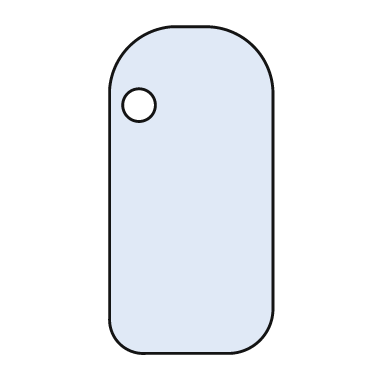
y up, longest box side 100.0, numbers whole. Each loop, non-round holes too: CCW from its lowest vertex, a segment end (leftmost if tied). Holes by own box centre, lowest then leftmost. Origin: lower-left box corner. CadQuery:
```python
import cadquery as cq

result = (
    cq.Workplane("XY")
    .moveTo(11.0, 0.0)
    .lineTo(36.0, 0.0)
    .threePointArc((46.0, 4.0), (50.0, 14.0))
    .lineTo(50.0, 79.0)
    .threePointArc((44.0, 94.0), (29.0, 100.0))
    .lineTo(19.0, 100.0)
    .threePointArc((6.0, 94.0), (0.0, 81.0))
    .lineTo(0.0, 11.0)
    .threePointArc((3.0, 3.0), (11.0, 0.0))
    .close()
    .moveTo(9.0, 76.0)
    .circle(5.0)
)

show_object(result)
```